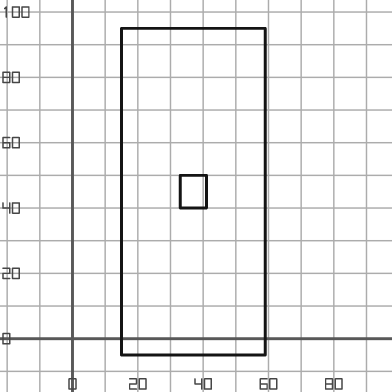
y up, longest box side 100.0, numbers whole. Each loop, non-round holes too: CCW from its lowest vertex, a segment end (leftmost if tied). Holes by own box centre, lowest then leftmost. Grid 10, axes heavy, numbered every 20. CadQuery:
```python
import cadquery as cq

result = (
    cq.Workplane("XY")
    .moveTo(15.0, -5.0)
    .lineTo(59.0, -5.0)
    .lineTo(59.0, 95.0)
    .lineTo(15.0, 95.0)
    .close()
    .moveTo(33.0, 40.0)
    .lineTo(41.0, 40.0)
    .lineTo(41.0, 50.0)
    .lineTo(33.0, 50.0)
    .close()
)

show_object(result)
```